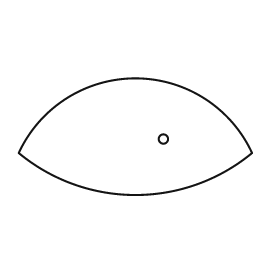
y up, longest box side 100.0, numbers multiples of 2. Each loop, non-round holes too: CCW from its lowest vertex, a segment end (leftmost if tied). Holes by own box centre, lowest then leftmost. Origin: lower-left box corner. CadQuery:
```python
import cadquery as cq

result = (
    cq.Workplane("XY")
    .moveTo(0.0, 18.0)
    .threePointArc((50.0, 0.0), (100.0, 18.0))
    .threePointArc((50.0, 50.0), (0.0, 18.0))
    .close()
    .moveTo(62.0, 24.0)
    .circle(2.0)
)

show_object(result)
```